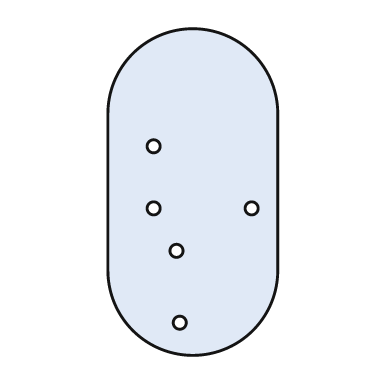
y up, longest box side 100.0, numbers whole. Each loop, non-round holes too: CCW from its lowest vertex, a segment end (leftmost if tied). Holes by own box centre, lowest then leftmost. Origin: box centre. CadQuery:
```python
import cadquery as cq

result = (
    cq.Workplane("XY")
    .moveTo(-26.0, -24.0)
    .threePointArc((0.0, -50.0), (26.0, -24.0))
    .lineTo(26.0, 24.0)
    .threePointArc((0.0, 50.0), (-26.0, 24.0))
    .close()
    .moveTo(-4.0, -40.0)
    .circle(2.0)
    .moveTo(-5.0, -18.0)
    .circle(2.0)
    .moveTo(-12.0, -5.0)
    .circle(2.0)
    .moveTo(18.0, -5.0)
    .circle(2.0)
    .moveTo(-12.0, 14.0)
    .circle(2.0)
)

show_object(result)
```